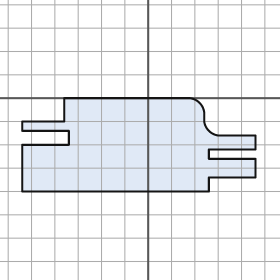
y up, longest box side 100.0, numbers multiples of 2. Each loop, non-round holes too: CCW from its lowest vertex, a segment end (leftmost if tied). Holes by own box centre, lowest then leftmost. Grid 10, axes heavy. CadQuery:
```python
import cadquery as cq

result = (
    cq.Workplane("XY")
    .moveTo(-54.0, -40.0)
    .lineTo(26.0, -40.0)
    .lineTo(26.0, -34.0)
    .lineTo(46.0, -34.0)
    .lineTo(46.0, -26.0)
    .lineTo(26.0, -26.0)
    .lineTo(26.0, -22.0)
    .lineTo(46.0, -22.0)
    .lineTo(46.0, -16.0)
    .lineTo(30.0, -16.0)
    .threePointArc((26.0, -14.0), (24.0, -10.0))
    .lineTo(24.0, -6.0)
    .threePointArc((22.0, -2.0), (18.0, 0.0))
    .lineTo(-36.0, 0.0)
    .lineTo(-36.0, -10.0)
    .lineTo(-54.0, -10.0)
    .lineTo(-54.0, -14.0)
    .lineTo(-34.0, -14.0)
    .lineTo(-34.0, -20.0)
    .lineTo(-54.0, -20.0)
    .close()
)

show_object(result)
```